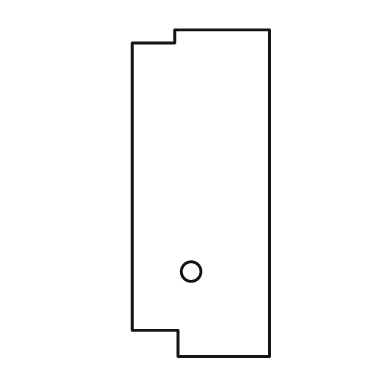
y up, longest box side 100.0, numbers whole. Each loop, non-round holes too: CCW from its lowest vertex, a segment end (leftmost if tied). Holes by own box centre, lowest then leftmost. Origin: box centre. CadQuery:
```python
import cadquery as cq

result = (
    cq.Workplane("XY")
    .moveTo(-7.0, -50.0)
    .lineTo(21.0, -50.0)
    .lineTo(21.0, 50.0)
    .lineTo(-8.0, 50.0)
    .lineTo(-8.0, 46.0)
    .lineTo(-21.0, 46.0)
    .lineTo(-21.0, -42.0)
    .lineTo(-7.0, -42.0)
    .close()
    .moveTo(-3.0, -24.0)
    .circle(3.0)
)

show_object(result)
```